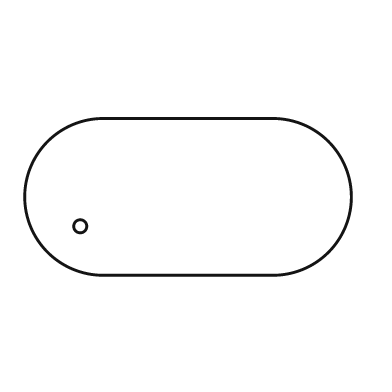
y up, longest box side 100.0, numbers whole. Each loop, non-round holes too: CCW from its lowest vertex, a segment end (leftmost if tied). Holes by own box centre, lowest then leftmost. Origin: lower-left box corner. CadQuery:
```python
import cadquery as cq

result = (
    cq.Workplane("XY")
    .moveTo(24.0, 0.0)
    .lineTo(76.0, 0.0)
    .threePointArc((100.0, 24.0), (76.0, 48.0))
    .lineTo(24.0, 48.0)
    .threePointArc((0.0, 24.0), (24.0, 0.0))
    .close()
    .moveTo(17.0, 15.0)
    .circle(2.0)
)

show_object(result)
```